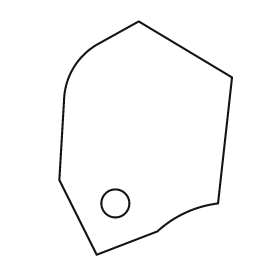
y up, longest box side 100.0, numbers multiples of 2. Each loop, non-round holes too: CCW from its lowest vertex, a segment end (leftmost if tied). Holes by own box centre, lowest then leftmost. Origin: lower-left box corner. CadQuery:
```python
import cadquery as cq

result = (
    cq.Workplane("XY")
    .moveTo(16.0, 0.0)
    .lineTo(42.0, 10.0)
    .threePointArc((54.0, 18.0), (68.0, 22.0))
    .lineTo(74.0, 76.0)
    .lineTo(34.0, 100.0)
    .lineTo(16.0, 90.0)
    .threePointArc((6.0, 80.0), (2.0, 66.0))
    .lineTo(0.0, 32.0)
    .close()
    .moveTo(24.0, 22.0)
    .circle(6.0)
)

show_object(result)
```